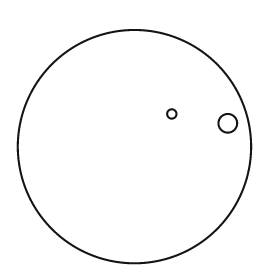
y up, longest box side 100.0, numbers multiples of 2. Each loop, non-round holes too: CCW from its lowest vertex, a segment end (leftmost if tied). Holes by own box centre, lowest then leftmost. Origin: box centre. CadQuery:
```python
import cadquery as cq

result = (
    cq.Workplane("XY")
    .moveTo(0.0, 0.0)
    .circle(50.0)
    .moveTo(40.0, 10.0)
    .circle(4.0)
    .moveTo(16.0, 14.0)
    .circle(2.0)
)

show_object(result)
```